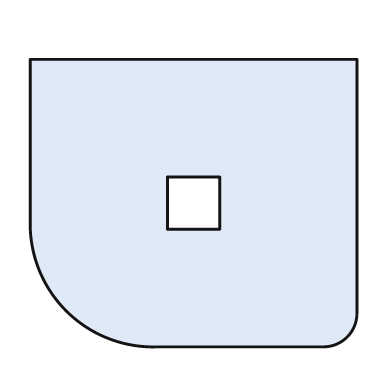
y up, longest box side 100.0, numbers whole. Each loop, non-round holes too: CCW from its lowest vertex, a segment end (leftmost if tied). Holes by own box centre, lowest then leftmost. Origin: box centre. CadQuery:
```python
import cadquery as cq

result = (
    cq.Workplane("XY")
    .moveTo(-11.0, -44.0)
    .lineTo(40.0, -44.0)
    .threePointArc((47.0, -41.0), (50.0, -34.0))
    .lineTo(50.0, 44.0)
    .lineTo(-50.0, 44.0)
    .lineTo(-50.0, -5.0)
    .threePointArc((-39.0, -33.0), (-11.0, -44.0))
    .close()
    .moveTo(-8.0, -8.0)
    .lineTo(8.0, -8.0)
    .lineTo(8.0, 8.0)
    .lineTo(-8.0, 8.0)
    .close()
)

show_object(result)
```